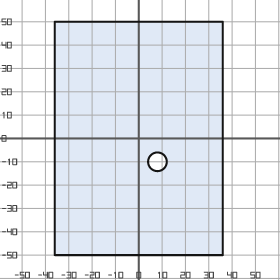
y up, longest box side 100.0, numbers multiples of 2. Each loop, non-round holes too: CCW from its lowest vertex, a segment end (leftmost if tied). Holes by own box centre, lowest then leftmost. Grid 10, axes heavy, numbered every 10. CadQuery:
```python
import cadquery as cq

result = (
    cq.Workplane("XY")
    .moveTo(-36.0, -50.0)
    .lineTo(36.0, -50.0)
    .lineTo(36.0, 50.0)
    .lineTo(-36.0, 50.0)
    .close()
    .moveTo(8.0, -10.0)
    .circle(4.0)
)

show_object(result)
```